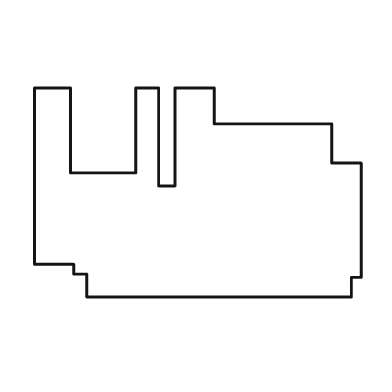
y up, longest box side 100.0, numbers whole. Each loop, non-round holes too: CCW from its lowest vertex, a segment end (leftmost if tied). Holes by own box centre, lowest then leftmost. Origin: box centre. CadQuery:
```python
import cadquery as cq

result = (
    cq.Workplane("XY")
    .moveTo(-34.0, -32.0)
    .lineTo(47.0, -32.0)
    .lineTo(47.0, -26.0)
    .lineTo(50.0, -26.0)
    .lineTo(50.0, 9.0)
    .lineTo(41.0, 9.0)
    .lineTo(41.0, 21.0)
    .lineTo(5.0, 21.0)
    .lineTo(5.0, 32.0)
    .lineTo(-7.0, 32.0)
    .lineTo(-7.0, 2.0)
    .lineTo(-12.0, 2.0)
    .lineTo(-12.0, 32.0)
    .lineTo(-19.0, 32.0)
    .lineTo(-19.0, 6.0)
    .lineTo(-39.0, 6.0)
    .lineTo(-39.0, 32.0)
    .lineTo(-50.0, 32.0)
    .lineTo(-50.0, -22.0)
    .lineTo(-38.0, -22.0)
    .lineTo(-38.0, -25.0)
    .lineTo(-34.0, -25.0)
    .close()
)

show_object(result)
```